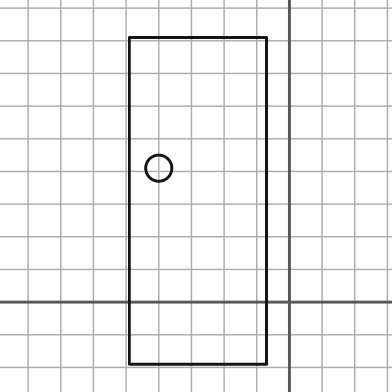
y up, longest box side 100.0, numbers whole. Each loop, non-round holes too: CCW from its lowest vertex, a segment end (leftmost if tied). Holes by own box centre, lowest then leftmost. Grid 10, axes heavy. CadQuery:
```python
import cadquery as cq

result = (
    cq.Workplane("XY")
    .moveTo(-49.0, -19.0)
    .lineTo(-7.0, -19.0)
    .lineTo(-7.0, 81.0)
    .lineTo(-49.0, 81.0)
    .close()
    .moveTo(-40.0, 41.0)
    .circle(4.0)
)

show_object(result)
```